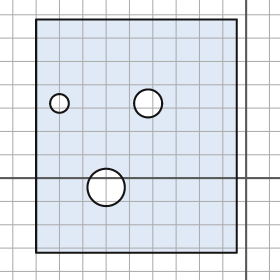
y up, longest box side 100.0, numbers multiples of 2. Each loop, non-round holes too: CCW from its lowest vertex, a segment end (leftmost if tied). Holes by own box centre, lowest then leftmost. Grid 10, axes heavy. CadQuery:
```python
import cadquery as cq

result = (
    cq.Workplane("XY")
    .moveTo(-90.0, -32.0)
    .lineTo(-4.0, -32.0)
    .lineTo(-4.0, 68.0)
    .lineTo(-90.0, 68.0)
    .close()
    .moveTo(-60.0, -4.0)
    .circle(8.0)
    .moveTo(-80.0, 32.0)
    .circle(4.0)
    .moveTo(-42.0, 32.0)
    .circle(6.0)
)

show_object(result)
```